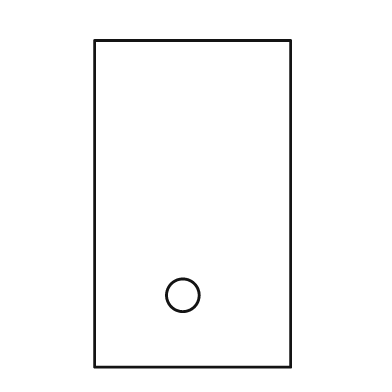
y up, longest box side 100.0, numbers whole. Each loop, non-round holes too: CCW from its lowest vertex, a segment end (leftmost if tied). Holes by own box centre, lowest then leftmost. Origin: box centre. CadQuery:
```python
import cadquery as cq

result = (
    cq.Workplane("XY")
    .moveTo(-30.0, -50.0)
    .lineTo(30.0, -50.0)
    .lineTo(30.0, 50.0)
    .lineTo(-30.0, 50.0)
    .close()
    .moveTo(-3.0, -28.0)
    .circle(5.0)
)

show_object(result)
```